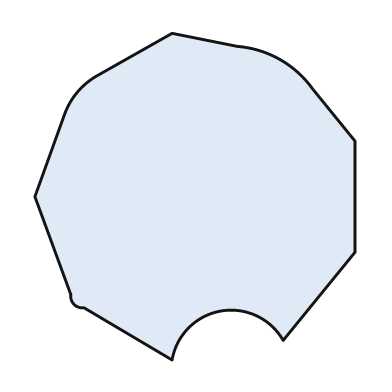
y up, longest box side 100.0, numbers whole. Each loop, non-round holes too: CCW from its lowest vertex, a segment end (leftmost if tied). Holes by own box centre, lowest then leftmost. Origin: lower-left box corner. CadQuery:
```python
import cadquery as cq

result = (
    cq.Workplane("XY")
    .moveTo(42.0, 0.0)
    .threePointArc((57.0, 15.0), (76.0, 6.0))
    .lineTo(98.0, 33.0)
    .lineTo(98.0, 67.0)
    .lineTo(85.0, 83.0)
    .threePointArc((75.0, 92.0), (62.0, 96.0))
    .lineTo(42.0, 100.0)
    .lineTo(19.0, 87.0)
    .threePointArc((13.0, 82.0), (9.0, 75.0))
    .lineTo(0.0, 50.0)
    .lineTo(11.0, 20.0)
    .threePointArc((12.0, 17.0), (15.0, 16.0))
    .close()
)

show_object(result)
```